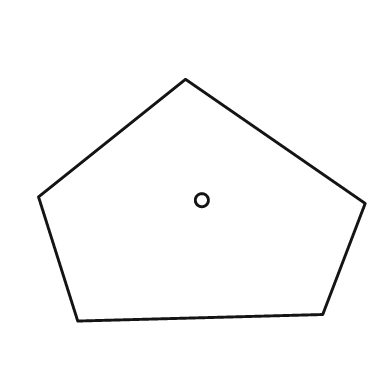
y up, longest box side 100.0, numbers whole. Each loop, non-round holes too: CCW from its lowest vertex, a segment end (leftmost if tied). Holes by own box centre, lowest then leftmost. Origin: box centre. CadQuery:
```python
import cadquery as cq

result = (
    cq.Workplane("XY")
    .moveTo(-38.0, -37.0)
    .lineTo(37.0, -35.0)
    .lineTo(50.0, -1.0)
    .lineTo(-5.0, 37.0)
    .lineTo(-50.0, 1.0)
    .close()
    .moveTo(0.0, 0.0)
    .circle(2.0)
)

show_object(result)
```